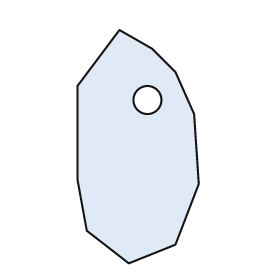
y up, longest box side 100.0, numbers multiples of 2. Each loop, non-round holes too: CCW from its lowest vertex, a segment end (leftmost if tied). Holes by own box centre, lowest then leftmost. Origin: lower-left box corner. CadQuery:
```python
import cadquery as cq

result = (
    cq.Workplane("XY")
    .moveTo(22.0, 0.0)
    .lineTo(42.0, 8.0)
    .lineTo(52.0, 34.0)
    .lineTo(50.0, 64.0)
    .lineTo(42.0, 82.0)
    .lineTo(32.0, 92.0)
    .lineTo(18.0, 100.0)
    .lineTo(0.0, 76.0)
    .lineTo(0.0, 36.0)
    .lineTo(4.0, 14.0)
    .close()
    .moveTo(30.0, 70.0)
    .circle(6.0)
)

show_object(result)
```